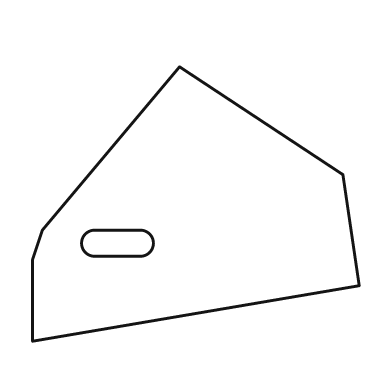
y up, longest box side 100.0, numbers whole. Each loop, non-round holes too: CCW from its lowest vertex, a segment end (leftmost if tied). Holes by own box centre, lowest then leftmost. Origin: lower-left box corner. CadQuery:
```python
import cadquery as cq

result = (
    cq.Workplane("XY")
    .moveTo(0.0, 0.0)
    .lineTo(100.0, 17.0)
    .lineTo(95.0, 51.0)
    .lineTo(45.0, 84.0)
    .lineTo(3.0, 34.0)
    .lineTo(0.0, 25.0)
    .close()
    .moveTo(19.0, 26.0)
    .lineTo(33.0, 26.0)
    .threePointArc((37.0, 30.0), (33.0, 34.0))
    .lineTo(19.0, 34.0)
    .threePointArc((15.0, 30.0), (19.0, 26.0))
    .close()
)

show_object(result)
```